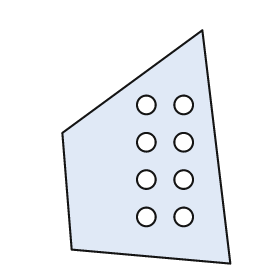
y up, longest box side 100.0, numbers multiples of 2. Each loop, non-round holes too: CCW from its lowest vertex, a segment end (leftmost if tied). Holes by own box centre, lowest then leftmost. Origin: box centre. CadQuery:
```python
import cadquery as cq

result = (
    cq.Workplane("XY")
    .moveTo(36.0, -50.0)
    .lineTo(24.0, 50.0)
    .lineTo(-36.0, 6.0)
    .lineTo(-32.0, -44.0)
    .close()
    .moveTo(0.0, -30.0)
    .circle(4.0)
    .moveTo(16.0, -30.0)
    .circle(4.0)
    .moveTo(0.0, -14.0)
    .circle(4.0)
    .moveTo(16.0, -14.0)
    .circle(4.0)
    .moveTo(0.0, 2.0)
    .circle(4.0)
    .moveTo(16.0, 2.0)
    .circle(4.0)
    .moveTo(0.0, 18.0)
    .circle(4.0)
    .moveTo(16.0, 18.0)
    .circle(4.0)
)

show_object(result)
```